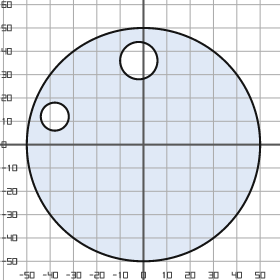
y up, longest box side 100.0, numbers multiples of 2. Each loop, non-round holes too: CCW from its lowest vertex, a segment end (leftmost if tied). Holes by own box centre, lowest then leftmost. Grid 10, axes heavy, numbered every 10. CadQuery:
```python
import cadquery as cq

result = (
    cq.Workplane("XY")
    .moveTo(0.0, 0.0)
    .circle(50.0)
    .moveTo(-38.0, 12.0)
    .circle(6.0)
    .moveTo(-2.0, 36.0)
    .circle(8.0)
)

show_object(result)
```